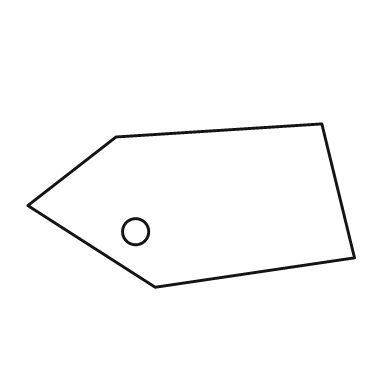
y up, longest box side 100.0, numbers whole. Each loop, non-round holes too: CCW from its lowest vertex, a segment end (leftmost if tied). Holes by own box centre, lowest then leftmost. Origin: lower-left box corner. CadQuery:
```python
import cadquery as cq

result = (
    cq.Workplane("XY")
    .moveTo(39.0, 0.0)
    .lineTo(100.0, 9.0)
    .lineTo(90.0, 50.0)
    .lineTo(27.0, 46.0)
    .lineTo(0.0, 25.0)
    .close()
    .moveTo(33.0, 17.0)
    .circle(4.0)
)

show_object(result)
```